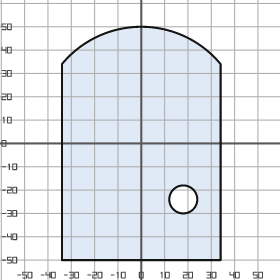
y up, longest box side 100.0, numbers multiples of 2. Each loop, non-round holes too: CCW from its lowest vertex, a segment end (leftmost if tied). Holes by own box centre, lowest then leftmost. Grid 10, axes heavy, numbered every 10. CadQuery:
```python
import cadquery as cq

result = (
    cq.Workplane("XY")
    .moveTo(-34.0, -50.0)
    .lineTo(34.0, -50.0)
    .lineTo(34.0, 34.0)
    .threePointArc((0.0, 50.0), (-34.0, 34.0))
    .close()
    .moveTo(18.0, -24.0)
    .circle(6.0)
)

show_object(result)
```